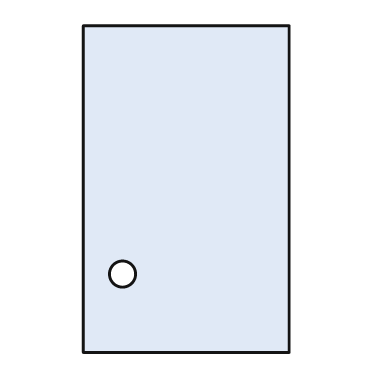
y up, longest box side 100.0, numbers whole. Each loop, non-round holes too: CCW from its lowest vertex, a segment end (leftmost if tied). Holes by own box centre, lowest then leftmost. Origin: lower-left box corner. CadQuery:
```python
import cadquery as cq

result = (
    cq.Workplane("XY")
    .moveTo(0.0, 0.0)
    .lineTo(63.0, 0.0)
    .lineTo(63.0, 100.0)
    .lineTo(0.0, 100.0)
    .close()
    .moveTo(12.0, 24.0)
    .circle(4.0)
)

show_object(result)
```